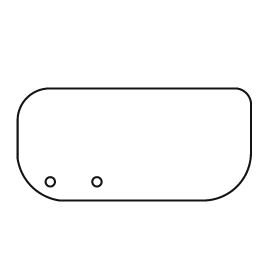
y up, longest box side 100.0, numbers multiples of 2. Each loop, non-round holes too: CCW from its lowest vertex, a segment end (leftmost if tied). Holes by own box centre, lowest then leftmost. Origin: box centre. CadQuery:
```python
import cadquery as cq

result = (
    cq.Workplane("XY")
    .moveTo(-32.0, -24.0)
    .lineTo(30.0, -24.0)
    .threePointArc((44.0, -18.0), (50.0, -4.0))
    .lineTo(50.0, 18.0)
    .threePointArc((48.0, 22.0), (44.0, 24.0))
    .lineTo(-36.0, 24.0)
    .threePointArc((-46.0, 20.0), (-50.0, 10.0))
    .lineTo(-50.0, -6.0)
    .threePointArc((-44.0, -18.0), (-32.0, -24.0))
    .close()
    .moveTo(-36.0, -16.0)
    .circle(2.0)
    .moveTo(-16.0, -16.0)
    .circle(2.0)
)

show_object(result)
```